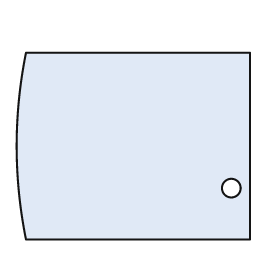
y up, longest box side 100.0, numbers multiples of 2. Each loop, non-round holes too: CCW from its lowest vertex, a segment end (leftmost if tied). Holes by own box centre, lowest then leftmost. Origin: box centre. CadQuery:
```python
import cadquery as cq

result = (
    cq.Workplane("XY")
    .moveTo(-46.0, -40.0)
    .lineTo(50.0, -40.0)
    .lineTo(50.0, 40.0)
    .lineTo(-46.0, 40.0)
    .threePointArc((-50.0, 0.0), (-46.0, -40.0))
    .close()
    .moveTo(42.0, -18.0)
    .circle(4.0)
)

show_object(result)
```